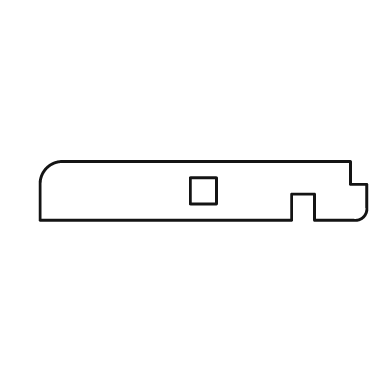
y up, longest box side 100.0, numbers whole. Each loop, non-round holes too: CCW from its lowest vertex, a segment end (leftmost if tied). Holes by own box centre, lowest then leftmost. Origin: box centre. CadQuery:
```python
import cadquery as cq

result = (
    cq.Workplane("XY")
    .moveTo(-50.0, -9.0)
    .lineTo(27.0, -9.0)
    .lineTo(27.0, -1.0)
    .lineTo(34.0, -1.0)
    .lineTo(34.0, -9.0)
    .lineTo(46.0, -9.0)
    .threePointArc((49.0, -8.0), (50.0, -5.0))
    .lineTo(50.0, 2.0)
    .lineTo(45.0, 2.0)
    .lineTo(45.0, 9.0)
    .lineTo(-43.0, 9.0)
    .threePointArc((-48.0, 7.0), (-50.0, 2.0))
    .close()
    .moveTo(-4.0, -4.0)
    .lineTo(4.0, -4.0)
    .lineTo(4.0, 4.0)
    .lineTo(-4.0, 4.0)
    .close()
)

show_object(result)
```